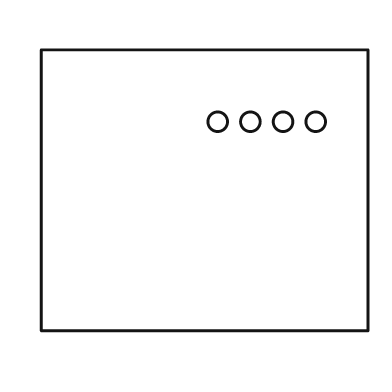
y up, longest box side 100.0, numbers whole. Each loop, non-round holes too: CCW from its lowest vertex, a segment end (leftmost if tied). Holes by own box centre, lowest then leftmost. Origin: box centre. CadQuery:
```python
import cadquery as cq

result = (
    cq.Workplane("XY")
    .moveTo(-50.0, -43.0)
    .lineTo(50.0, -43.0)
    .lineTo(50.0, 43.0)
    .lineTo(-50.0, 43.0)
    .close()
    .moveTo(4.0, 21.0)
    .circle(3.0)
    .moveTo(14.0, 21.0)
    .circle(3.0)
    .moveTo(24.0, 21.0)
    .circle(3.0)
    .moveTo(34.0, 21.0)
    .circle(3.0)
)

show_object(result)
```